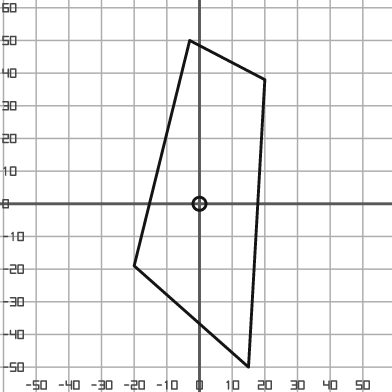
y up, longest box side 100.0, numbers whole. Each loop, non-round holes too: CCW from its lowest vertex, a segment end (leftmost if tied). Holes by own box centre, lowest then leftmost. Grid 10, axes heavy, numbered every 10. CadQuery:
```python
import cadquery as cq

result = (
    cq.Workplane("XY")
    .moveTo(15.0, -50.0)
    .lineTo(20.0, 38.0)
    .lineTo(-3.0, 50.0)
    .lineTo(-20.0, -19.0)
    .close()
    .moveTo(0.0, 0.0)
    .circle(2.0)
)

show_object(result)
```